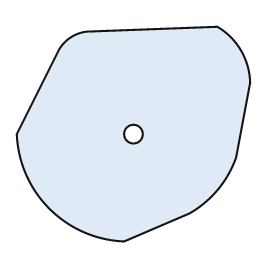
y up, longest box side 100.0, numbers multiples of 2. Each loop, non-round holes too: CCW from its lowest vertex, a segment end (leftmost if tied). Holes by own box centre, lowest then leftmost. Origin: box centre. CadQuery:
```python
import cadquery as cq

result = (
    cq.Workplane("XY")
    .moveTo(-4.0, -46.0)
    .lineTo(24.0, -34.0)
    .threePointArc((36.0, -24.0), (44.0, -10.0))
    .lineTo(50.0, 22.0)
    .threePointArc((46.0, 36.0), (36.0, 46.0))
    .lineTo(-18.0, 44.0)
    .threePointArc((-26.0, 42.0), (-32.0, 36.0))
    .lineTo(-50.0, 0.0)
    .threePointArc((-36.0, -32.0), (-4.0, -46.0))
    .close()
    .moveTo(0.0, 0.0)
    .circle(4.0)
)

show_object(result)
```